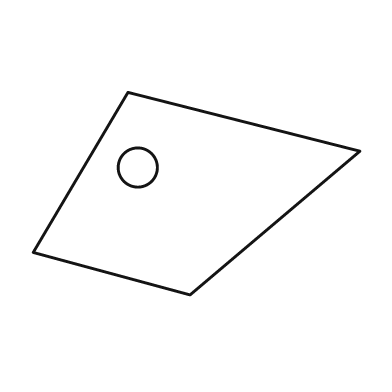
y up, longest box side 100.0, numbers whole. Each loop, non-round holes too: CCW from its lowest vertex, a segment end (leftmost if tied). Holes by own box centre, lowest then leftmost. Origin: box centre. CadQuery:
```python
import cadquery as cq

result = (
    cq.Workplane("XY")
    .moveTo(-2.0, -31.0)
    .lineTo(50.0, 13.0)
    .lineTo(-21.0, 31.0)
    .lineTo(-50.0, -18.0)
    .close()
    .moveTo(-18.0, 8.0)
    .circle(6.0)
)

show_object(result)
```